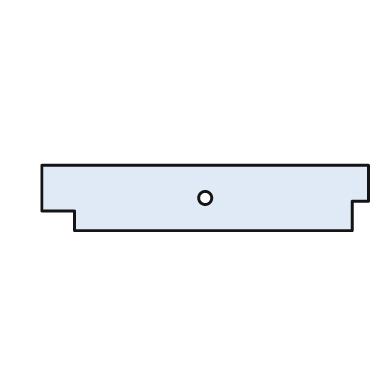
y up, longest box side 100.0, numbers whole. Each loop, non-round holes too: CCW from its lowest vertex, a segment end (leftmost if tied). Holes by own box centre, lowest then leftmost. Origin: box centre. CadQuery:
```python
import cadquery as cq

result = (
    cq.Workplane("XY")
    .moveTo(-40.0, -10.0)
    .lineTo(45.0, -10.0)
    .lineTo(45.0, -1.0)
    .lineTo(50.0, -1.0)
    .lineTo(50.0, 10.0)
    .lineTo(-50.0, 10.0)
    .lineTo(-50.0, -4.0)
    .lineTo(-40.0, -4.0)
    .close()
    .moveTo(0.0, 0.0)
    .circle(2.0)
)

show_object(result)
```